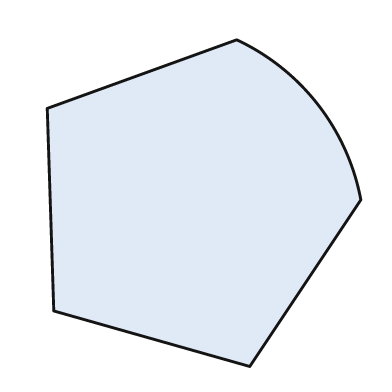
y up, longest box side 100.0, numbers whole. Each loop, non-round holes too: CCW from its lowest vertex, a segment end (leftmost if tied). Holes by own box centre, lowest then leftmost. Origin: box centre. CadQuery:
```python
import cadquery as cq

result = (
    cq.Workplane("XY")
    .moveTo(14.0, -50.0)
    .lineTo(48.0, 1.0)
    .threePointArc((35.0, 30.0), (10.0, 50.0))
    .lineTo(-48.0, 29.0)
    .lineTo(-46.0, -33.0)
    .close()
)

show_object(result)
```